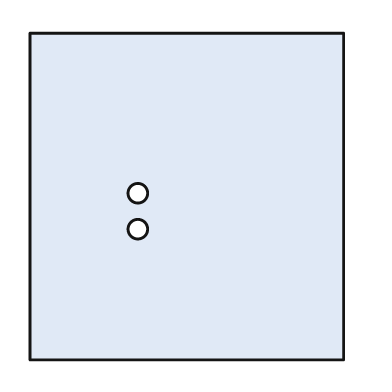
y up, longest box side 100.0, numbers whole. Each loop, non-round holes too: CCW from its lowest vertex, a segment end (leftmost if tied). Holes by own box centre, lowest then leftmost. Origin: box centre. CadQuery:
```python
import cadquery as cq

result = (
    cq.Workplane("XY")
    .moveTo(-48.0, -50.0)
    .lineTo(48.0, -50.0)
    .lineTo(48.0, 50.0)
    .lineTo(-48.0, 50.0)
    .close()
    .moveTo(-15.0, -10.0)
    .circle(3.0)
    .moveTo(-15.0, 1.0)
    .circle(3.0)
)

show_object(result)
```